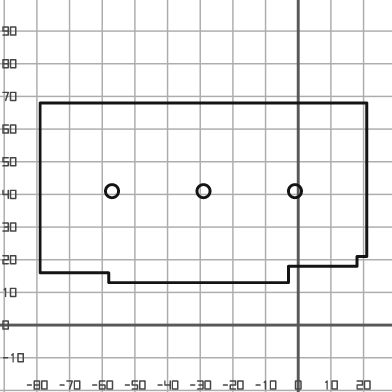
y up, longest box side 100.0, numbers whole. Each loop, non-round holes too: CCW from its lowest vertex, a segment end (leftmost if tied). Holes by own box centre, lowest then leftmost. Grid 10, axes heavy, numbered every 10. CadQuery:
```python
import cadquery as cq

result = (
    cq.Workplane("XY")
    .moveTo(-58.0, 13.0)
    .lineTo(-3.0, 13.0)
    .lineTo(-3.0, 18.0)
    .lineTo(18.0, 18.0)
    .lineTo(18.0, 21.0)
    .lineTo(21.0, 21.0)
    .lineTo(21.0, 68.0)
    .lineTo(-79.0, 68.0)
    .lineTo(-79.0, 16.0)
    .lineTo(-58.0, 16.0)
    .close()
    .moveTo(-57.0, 41.0)
    .circle(2.0)
    .moveTo(-29.0, 41.0)
    .circle(2.0)
    .moveTo(-1.0, 41.0)
    .circle(2.0)
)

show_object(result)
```